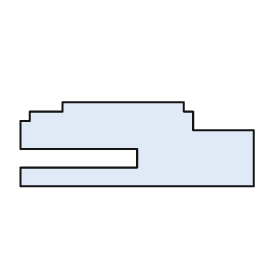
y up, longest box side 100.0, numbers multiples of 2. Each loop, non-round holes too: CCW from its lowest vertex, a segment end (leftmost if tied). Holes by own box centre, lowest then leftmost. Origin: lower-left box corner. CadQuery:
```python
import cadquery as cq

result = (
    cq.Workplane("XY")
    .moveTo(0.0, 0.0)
    .lineTo(100.0, 0.0)
    .lineTo(100.0, 24.0)
    .lineTo(74.0, 24.0)
    .lineTo(74.0, 32.0)
    .lineTo(70.0, 32.0)
    .lineTo(70.0, 36.0)
    .lineTo(18.0, 36.0)
    .lineTo(18.0, 32.0)
    .lineTo(4.0, 32.0)
    .lineTo(4.0, 28.0)
    .lineTo(0.0, 28.0)
    .lineTo(0.0, 16.0)
    .lineTo(50.0, 16.0)
    .lineTo(50.0, 8.0)
    .lineTo(0.0, 8.0)
    .close()
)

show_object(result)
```